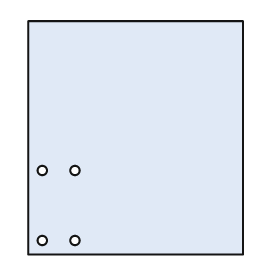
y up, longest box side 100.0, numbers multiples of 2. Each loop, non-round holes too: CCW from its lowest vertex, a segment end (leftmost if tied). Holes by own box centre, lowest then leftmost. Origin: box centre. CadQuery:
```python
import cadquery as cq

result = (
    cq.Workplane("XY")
    .moveTo(-46.0, -50.0)
    .lineTo(46.0, -50.0)
    .lineTo(46.0, 50.0)
    .lineTo(-46.0, 50.0)
    .close()
    .moveTo(-40.0, -44.0)
    .circle(2.0)
    .moveTo(-26.0, -44.0)
    .circle(2.0)
    .moveTo(-40.0, -14.0)
    .circle(2.0)
    .moveTo(-26.0, -14.0)
    .circle(2.0)
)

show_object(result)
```